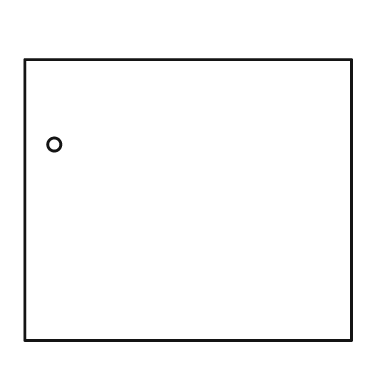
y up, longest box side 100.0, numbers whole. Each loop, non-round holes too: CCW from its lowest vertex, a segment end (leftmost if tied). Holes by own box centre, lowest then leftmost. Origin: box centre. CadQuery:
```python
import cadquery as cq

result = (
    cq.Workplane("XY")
    .moveTo(-50.0, -43.0)
    .lineTo(50.0, -43.0)
    .lineTo(50.0, 43.0)
    .lineTo(-50.0, 43.0)
    .close()
    .moveTo(-41.0, 17.0)
    .circle(2.0)
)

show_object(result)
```